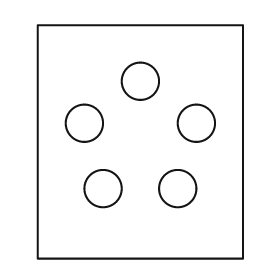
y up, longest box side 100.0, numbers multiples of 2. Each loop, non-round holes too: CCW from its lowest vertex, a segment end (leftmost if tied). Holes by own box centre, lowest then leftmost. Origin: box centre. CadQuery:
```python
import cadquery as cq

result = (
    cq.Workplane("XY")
    .moveTo(-44.0, -50.0)
    .lineTo(44.0, -50.0)
    .lineTo(44.0, 50.0)
    .lineTo(-44.0, 50.0)
    .close()
    .moveTo(-16.0, -20.0)
    .circle(8.0)
    .moveTo(16.0, -20.0)
    .circle(8.0)
    .moveTo(-24.0, 8.0)
    .circle(8.0)
    .moveTo(24.0, 8.0)
    .circle(8.0)
    .moveTo(0.0, 26.0)
    .circle(8.0)
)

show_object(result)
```